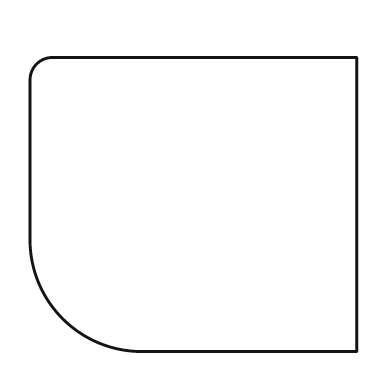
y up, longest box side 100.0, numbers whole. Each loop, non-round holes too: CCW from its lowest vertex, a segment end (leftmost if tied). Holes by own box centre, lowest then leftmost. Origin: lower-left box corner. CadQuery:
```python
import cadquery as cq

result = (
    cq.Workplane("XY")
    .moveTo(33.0, 0.0)
    .lineTo(100.0, 0.0)
    .lineTo(100.0, 90.0)
    .lineTo(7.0, 90.0)
    .threePointArc((2.0, 88.0), (0.0, 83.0))
    .lineTo(0.0, 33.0)
    .threePointArc((10.0, 10.0), (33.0, 0.0))
    .close()
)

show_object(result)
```